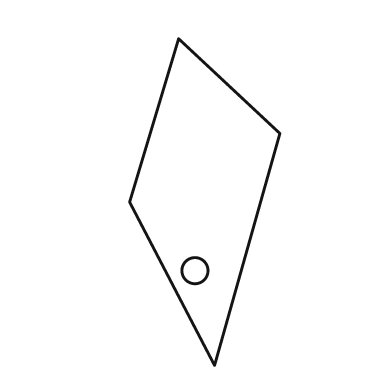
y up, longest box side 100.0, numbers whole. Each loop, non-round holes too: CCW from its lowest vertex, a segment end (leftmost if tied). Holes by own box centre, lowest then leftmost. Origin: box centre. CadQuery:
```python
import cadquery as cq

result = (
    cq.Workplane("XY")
    .moveTo(3.0, -50.0)
    .lineTo(23.0, 21.0)
    .lineTo(-8.0, 50.0)
    .lineTo(-23.0, 0.0)
    .close()
    .moveTo(-3.0, -21.0)
    .circle(4.0)
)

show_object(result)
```